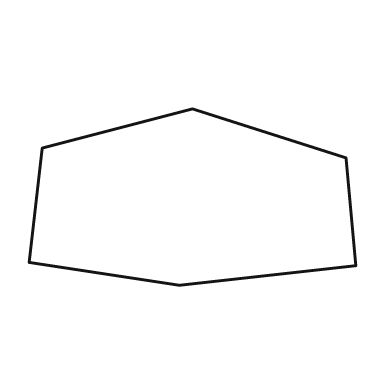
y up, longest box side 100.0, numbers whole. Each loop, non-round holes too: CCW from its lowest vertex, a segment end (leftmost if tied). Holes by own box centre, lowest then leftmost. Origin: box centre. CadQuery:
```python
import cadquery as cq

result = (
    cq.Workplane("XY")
    .moveTo(-4.0, -27.0)
    .lineTo(50.0, -21.0)
    .lineTo(47.0, 12.0)
    .lineTo(0.0, 27.0)
    .lineTo(-46.0, 15.0)
    .lineTo(-50.0, -20.0)
    .close()
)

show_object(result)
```